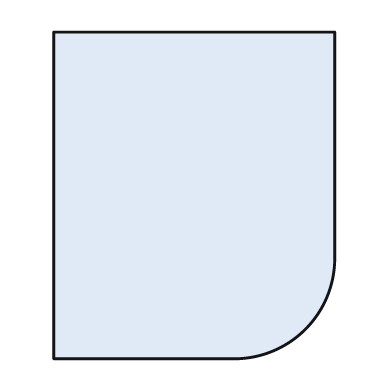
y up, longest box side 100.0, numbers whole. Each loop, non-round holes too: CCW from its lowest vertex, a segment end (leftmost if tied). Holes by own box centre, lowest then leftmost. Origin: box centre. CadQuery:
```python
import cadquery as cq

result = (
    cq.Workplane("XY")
    .moveTo(-43.0, -50.0)
    .lineTo(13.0, -50.0)
    .threePointArc((34.0, -41.0), (43.0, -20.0))
    .lineTo(43.0, 50.0)
    .lineTo(-43.0, 50.0)
    .close()
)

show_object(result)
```